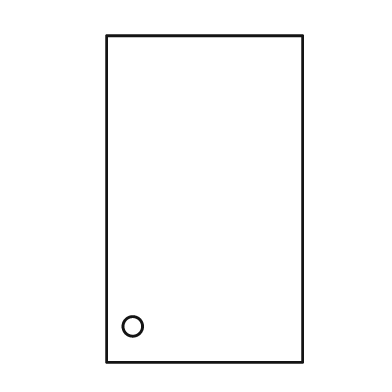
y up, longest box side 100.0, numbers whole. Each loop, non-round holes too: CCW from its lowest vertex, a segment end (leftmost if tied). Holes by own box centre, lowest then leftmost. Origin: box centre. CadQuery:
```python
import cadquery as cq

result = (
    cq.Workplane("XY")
    .moveTo(-30.0, -50.0)
    .lineTo(30.0, -50.0)
    .lineTo(30.0, 50.0)
    .lineTo(-30.0, 50.0)
    .close()
    .moveTo(-22.0, -39.0)
    .circle(3.0)
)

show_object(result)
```